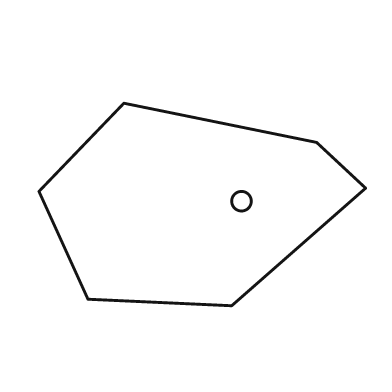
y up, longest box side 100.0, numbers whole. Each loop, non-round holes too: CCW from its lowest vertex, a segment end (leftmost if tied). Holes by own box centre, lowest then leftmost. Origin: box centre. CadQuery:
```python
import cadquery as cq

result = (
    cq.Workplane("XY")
    .moveTo(9.0, -31.0)
    .lineTo(50.0, 5.0)
    .lineTo(35.0, 19.0)
    .lineTo(-24.0, 31.0)
    .lineTo(-50.0, 4.0)
    .lineTo(-35.0, -29.0)
    .close()
    .moveTo(12.0, 1.0)
    .circle(3.0)
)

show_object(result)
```